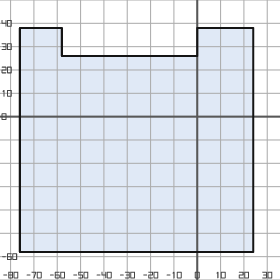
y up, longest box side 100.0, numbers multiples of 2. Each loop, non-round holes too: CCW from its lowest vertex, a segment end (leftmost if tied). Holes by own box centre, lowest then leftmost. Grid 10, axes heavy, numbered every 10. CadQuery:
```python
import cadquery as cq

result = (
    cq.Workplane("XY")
    .moveTo(-76.0, -58.0)
    .lineTo(24.0, -58.0)
    .lineTo(24.0, 38.0)
    .lineTo(0.0, 38.0)
    .lineTo(0.0, 26.0)
    .lineTo(-58.0, 26.0)
    .lineTo(-58.0, 38.0)
    .lineTo(-76.0, 38.0)
    .close()
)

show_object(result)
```